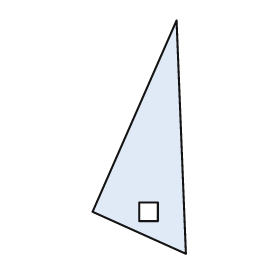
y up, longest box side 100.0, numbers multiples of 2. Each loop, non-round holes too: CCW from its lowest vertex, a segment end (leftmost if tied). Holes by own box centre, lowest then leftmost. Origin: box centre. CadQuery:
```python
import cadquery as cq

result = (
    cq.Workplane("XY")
    .moveTo(20.0, -50.0)
    .lineTo(16.0, 50.0)
    .lineTo(-20.0, -32.0)
    .close()
    .moveTo(0.0, -36.0)
    .lineTo(8.0, -36.0)
    .lineTo(8.0, -28.0)
    .lineTo(0.0, -28.0)
    .close()
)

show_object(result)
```